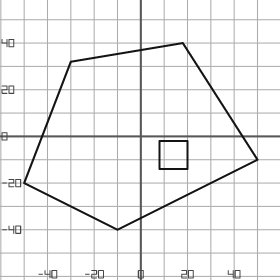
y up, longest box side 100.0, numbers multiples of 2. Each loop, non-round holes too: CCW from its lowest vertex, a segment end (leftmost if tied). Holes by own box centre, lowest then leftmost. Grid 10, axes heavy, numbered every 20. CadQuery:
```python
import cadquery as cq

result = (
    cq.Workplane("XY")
    .moveTo(-10.0, -40.0)
    .lineTo(50.0, -10.0)
    .lineTo(18.0, 40.0)
    .lineTo(-30.0, 32.0)
    .lineTo(-50.0, -20.0)
    .close()
    .moveTo(8.0, -14.0)
    .lineTo(20.0, -14.0)
    .lineTo(20.0, -2.0)
    .lineTo(8.0, -2.0)
    .close()
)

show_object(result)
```